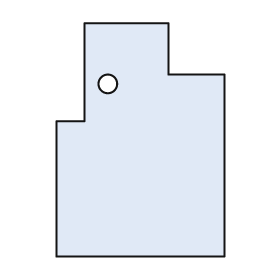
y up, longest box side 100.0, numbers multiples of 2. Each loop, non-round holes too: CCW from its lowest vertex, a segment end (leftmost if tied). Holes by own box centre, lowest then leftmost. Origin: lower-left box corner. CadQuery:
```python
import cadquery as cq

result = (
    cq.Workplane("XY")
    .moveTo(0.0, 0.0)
    .lineTo(72.0, 0.0)
    .lineTo(72.0, 78.0)
    .lineTo(48.0, 78.0)
    .lineTo(48.0, 100.0)
    .lineTo(12.0, 100.0)
    .lineTo(12.0, 58.0)
    .lineTo(0.0, 58.0)
    .close()
    .moveTo(22.0, 74.0)
    .circle(4.0)
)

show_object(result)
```